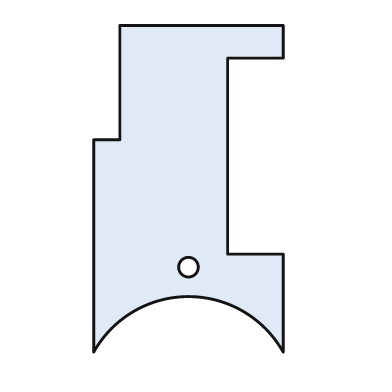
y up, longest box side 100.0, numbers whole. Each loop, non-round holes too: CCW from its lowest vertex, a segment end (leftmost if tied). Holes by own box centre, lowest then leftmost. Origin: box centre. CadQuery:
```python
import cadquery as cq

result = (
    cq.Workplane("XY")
    .moveTo(-29.0, -50.0)
    .threePointArc((0.0, -33.0), (29.0, -50.0))
    .lineTo(29.0, -20.0)
    .lineTo(12.0, -20.0)
    .lineTo(12.0, 40.0)
    .lineTo(29.0, 40.0)
    .lineTo(29.0, 50.0)
    .lineTo(-21.0, 50.0)
    .lineTo(-21.0, 15.0)
    .lineTo(-29.0, 15.0)
    .close()
    .moveTo(0.0, -24.0)
    .circle(3.0)
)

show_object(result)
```